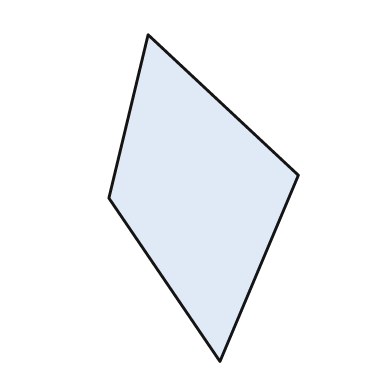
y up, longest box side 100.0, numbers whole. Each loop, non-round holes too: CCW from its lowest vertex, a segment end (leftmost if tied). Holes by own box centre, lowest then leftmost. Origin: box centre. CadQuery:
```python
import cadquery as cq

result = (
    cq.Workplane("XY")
    .moveTo(5.0, -50.0)
    .lineTo(29.0, 7.0)
    .lineTo(-17.0, 50.0)
    .lineTo(-29.0, 0.0)
    .close()
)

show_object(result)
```